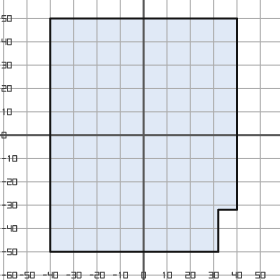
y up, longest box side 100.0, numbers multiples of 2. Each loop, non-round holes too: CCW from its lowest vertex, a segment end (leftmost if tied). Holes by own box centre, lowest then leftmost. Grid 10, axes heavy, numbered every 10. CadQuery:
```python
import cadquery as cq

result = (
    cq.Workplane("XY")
    .moveTo(-40.0, -50.0)
    .lineTo(32.0, -50.0)
    .lineTo(32.0, -32.0)
    .lineTo(40.0, -32.0)
    .lineTo(40.0, 50.0)
    .lineTo(-40.0, 50.0)
    .close()
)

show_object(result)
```